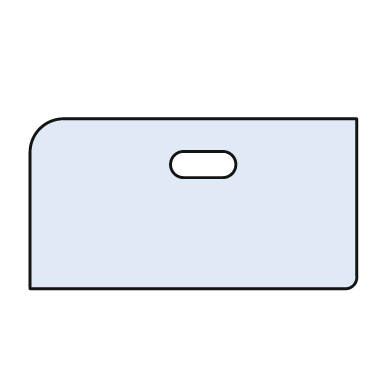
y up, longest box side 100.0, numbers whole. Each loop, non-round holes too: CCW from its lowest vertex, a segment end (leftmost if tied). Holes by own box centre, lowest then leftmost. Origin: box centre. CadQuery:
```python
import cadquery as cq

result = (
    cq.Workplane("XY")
    .moveTo(-50.0, -26.0)
    .lineTo(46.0, -26.0)
    .threePointArc((49.0, -25.0), (50.0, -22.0))
    .lineTo(50.0, 26.0)
    .lineTo(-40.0, 26.0)
    .threePointArc((-47.0, 23.0), (-50.0, 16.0))
    .close()
    .moveTo(-3.0, 8.0)
    .lineTo(9.0, 8.0)
    .threePointArc((13.0, 12.0), (9.0, 16.0))
    .lineTo(-3.0, 16.0)
    .threePointArc((-7.0, 12.0), (-3.0, 8.0))
    .close()
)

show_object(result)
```